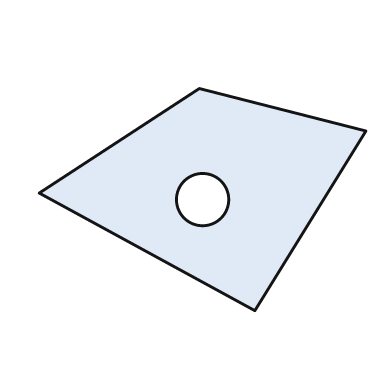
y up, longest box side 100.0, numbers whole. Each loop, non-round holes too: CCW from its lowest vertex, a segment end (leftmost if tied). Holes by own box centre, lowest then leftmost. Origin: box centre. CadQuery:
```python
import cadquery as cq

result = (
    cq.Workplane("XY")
    .moveTo(16.0, -34.0)
    .lineTo(50.0, 21.0)
    .lineTo(-1.0, 34.0)
    .lineTo(-50.0, 2.0)
    .close()
    .moveTo(0.0, 0.0)
    .circle(8.0)
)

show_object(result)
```